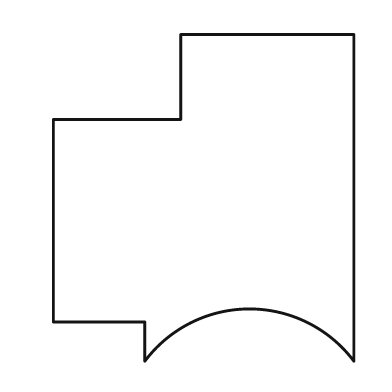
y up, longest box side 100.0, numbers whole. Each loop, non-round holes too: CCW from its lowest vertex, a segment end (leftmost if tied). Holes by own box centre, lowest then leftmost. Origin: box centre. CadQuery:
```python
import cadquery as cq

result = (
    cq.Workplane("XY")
    .moveTo(-18.0, -50.0)
    .threePointArc((14.0, -34.0), (46.0, -50.0))
    .lineTo(46.0, 50.0)
    .lineTo(-7.0, 50.0)
    .lineTo(-7.0, 24.0)
    .lineTo(-46.0, 24.0)
    .lineTo(-46.0, -38.0)
    .lineTo(-18.0, -38.0)
    .close()
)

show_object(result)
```